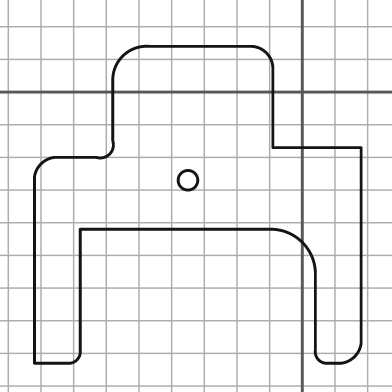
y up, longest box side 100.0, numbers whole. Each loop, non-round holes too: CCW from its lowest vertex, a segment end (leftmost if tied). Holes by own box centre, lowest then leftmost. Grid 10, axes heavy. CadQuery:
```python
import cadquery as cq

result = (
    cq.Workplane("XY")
    .moveTo(-82.0, -83.0)
    .lineTo(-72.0, -83.0)
    .threePointArc((-69.0, -82.0), (-68.0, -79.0))
    .lineTo(-68.0, -42.0)
    .lineTo(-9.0, -42.0)
    .threePointArc((0.0, -46.0), (4.0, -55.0))
    .lineTo(4.0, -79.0)
    .threePointArc((5.0, -82.0), (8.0, -83.0))
    .lineTo(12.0, -83.0)
    .threePointArc((16.0, -81.0), (18.0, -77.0))
    .lineTo(18.0, -17.0)
    .lineTo(-9.0, -17.0)
    .lineTo(-9.0, 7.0)
    .threePointArc((-11.0, 12.0), (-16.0, 14.0))
    .lineTo(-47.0, 14.0)
    .threePointArc((-55.0, 11.0), (-58.0, 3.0))
    .lineTo(-58.0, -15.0)
    .threePointArc((-59.0, -19.0), (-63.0, -20.0))
    .lineTo(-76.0, -20.0)
    .threePointArc((-80.0, -22.0), (-82.0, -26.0))
    .close()
    .moveTo(-35.0, -27.0)
    .circle(3.0)
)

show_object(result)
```